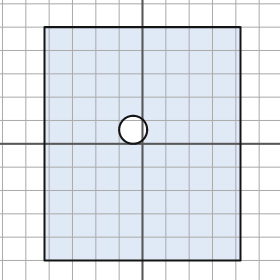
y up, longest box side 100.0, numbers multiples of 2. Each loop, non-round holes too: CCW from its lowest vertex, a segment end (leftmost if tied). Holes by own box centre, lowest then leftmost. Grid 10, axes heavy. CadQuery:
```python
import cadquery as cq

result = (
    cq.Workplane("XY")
    .moveTo(-42.0, -50.0)
    .lineTo(42.0, -50.0)
    .lineTo(42.0, 50.0)
    .lineTo(-42.0, 50.0)
    .close()
    .moveTo(-4.0, 6.0)
    .circle(6.0)
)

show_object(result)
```